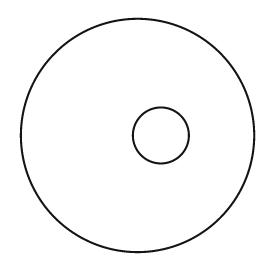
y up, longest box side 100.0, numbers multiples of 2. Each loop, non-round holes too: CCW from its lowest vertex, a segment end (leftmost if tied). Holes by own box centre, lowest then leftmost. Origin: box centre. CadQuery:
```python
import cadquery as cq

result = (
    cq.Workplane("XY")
    .moveTo(0.0, 0.0)
    .circle(50.0)
    .moveTo(10.0, 0.0)
    .circle(12.0)
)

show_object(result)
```